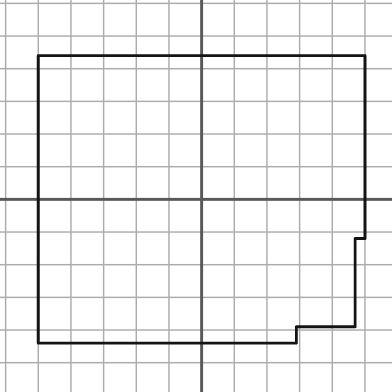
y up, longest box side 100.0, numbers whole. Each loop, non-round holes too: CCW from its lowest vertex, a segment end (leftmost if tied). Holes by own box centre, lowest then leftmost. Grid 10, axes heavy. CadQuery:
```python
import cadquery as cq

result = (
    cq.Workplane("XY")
    .moveTo(-50.0, -44.0)
    .lineTo(29.0, -44.0)
    .lineTo(29.0, -39.0)
    .lineTo(47.0, -39.0)
    .lineTo(47.0, -12.0)
    .lineTo(50.0, -12.0)
    .lineTo(50.0, 44.0)
    .lineTo(-50.0, 44.0)
    .close()
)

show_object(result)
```